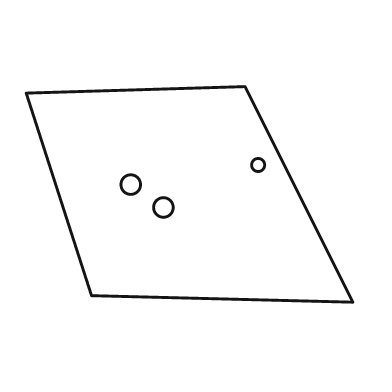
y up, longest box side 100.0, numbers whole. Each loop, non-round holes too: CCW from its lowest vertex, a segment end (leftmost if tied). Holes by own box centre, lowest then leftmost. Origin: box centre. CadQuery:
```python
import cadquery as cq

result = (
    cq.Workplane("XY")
    .moveTo(50.0, -33.0)
    .lineTo(17.0, 33.0)
    .lineTo(-50.0, 31.0)
    .lineTo(-30.0, -31.0)
    .close()
    .moveTo(-8.0, -4.0)
    .circle(3.0)
    .moveTo(-18.0, 3.0)
    .circle(3.0)
    .moveTo(21.0, 9.0)
    .circle(2.0)
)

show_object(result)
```